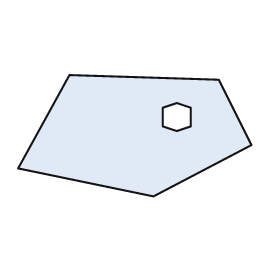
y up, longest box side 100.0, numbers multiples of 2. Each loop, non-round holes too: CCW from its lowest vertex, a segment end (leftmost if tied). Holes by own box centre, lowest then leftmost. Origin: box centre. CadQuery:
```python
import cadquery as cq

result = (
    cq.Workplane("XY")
    .moveTo(8.0, -26.0)
    .lineTo(50.0, -4.0)
    .lineTo(36.0, 24.0)
    .lineTo(-28.0, 26.0)
    .lineTo(-50.0, -14.0)
    .close()
    .moveTo(18.0, 2.0)
    .lineTo(24.0, 4.0)
    .lineTo(24.0, 12.0)
    .lineTo(18.0, 14.0)
    .lineTo(12.0, 12.0)
    .lineTo(12.0, 4.0)
    .close()
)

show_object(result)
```